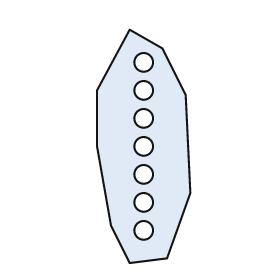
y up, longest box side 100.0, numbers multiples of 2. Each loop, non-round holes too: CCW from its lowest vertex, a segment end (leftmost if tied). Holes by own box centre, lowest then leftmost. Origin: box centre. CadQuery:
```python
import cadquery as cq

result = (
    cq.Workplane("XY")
    .moveTo(-6.0, -50.0)
    .lineTo(10.0, -48.0)
    .lineTo(20.0, -20.0)
    .lineTo(18.0, 22.0)
    .lineTo(8.0, 42.0)
    .lineTo(-6.0, 50.0)
    .lineTo(-20.0, 24.0)
    .lineTo(-20.0, 0.0)
    .lineTo(-14.0, -34.0)
    .close()
    .moveTo(0.0, -36.0)
    .circle(4.0)
    .moveTo(0.0, -24.0)
    .circle(4.0)
    .moveTo(0.0, -12.0)
    .circle(4.0)
    .moveTo(0.0, 0.0)
    .circle(4.0)
    .moveTo(0.0, 12.0)
    .circle(4.0)
    .moveTo(0.0, 24.0)
    .circle(4.0)
    .moveTo(0.0, 36.0)
    .circle(4.0)
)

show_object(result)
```